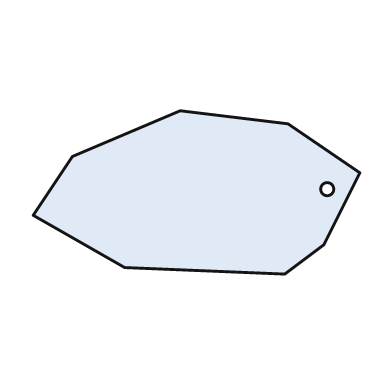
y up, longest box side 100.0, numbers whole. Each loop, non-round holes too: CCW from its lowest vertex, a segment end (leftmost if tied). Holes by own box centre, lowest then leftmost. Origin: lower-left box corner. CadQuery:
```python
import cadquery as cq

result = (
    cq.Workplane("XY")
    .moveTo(77.0, 0.0)
    .lineTo(89.0, 9.0)
    .lineTo(100.0, 31.0)
    .lineTo(78.0, 46.0)
    .lineTo(45.0, 50.0)
    .lineTo(12.0, 36.0)
    .lineTo(0.0, 18.0)
    .lineTo(28.0, 2.0)
    .close()
    .moveTo(90.0, 26.0)
    .circle(2.0)
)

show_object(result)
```